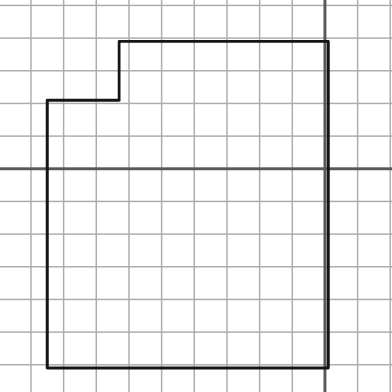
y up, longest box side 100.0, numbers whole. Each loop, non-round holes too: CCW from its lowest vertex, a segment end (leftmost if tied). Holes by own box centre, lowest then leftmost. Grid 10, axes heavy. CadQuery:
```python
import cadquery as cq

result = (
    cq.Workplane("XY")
    .moveTo(-85.0, -61.0)
    .lineTo(1.0, -61.0)
    .lineTo(1.0, 39.0)
    .lineTo(-63.0, 39.0)
    .lineTo(-63.0, 21.0)
    .lineTo(-85.0, 21.0)
    .close()
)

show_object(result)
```